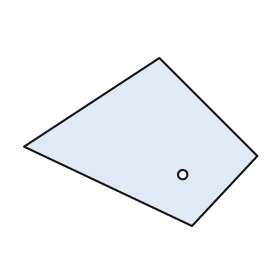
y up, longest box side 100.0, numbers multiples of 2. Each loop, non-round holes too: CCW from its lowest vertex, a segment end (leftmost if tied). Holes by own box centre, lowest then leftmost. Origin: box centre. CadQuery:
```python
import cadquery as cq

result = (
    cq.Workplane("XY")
    .moveTo(22.0, -36.0)
    .lineTo(50.0, -6.0)
    .lineTo(8.0, 36.0)
    .lineTo(-50.0, -2.0)
    .close()
    .moveTo(18.0, -14.0)
    .circle(2.0)
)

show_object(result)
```